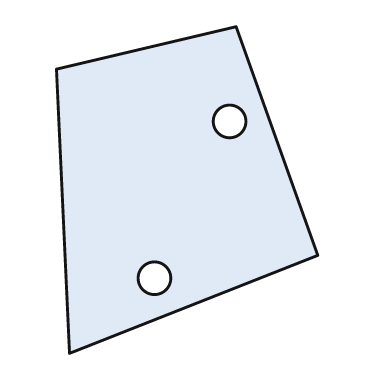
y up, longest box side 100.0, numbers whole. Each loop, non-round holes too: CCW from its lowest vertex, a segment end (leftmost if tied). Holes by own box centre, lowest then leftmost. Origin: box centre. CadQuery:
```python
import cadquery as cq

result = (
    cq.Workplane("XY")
    .moveTo(-36.0, -50.0)
    .lineTo(40.0, -20.0)
    .lineTo(15.0, 50.0)
    .lineTo(-40.0, 37.0)
    .close()
    .moveTo(-10.0, -27.0)
    .circle(5.0)
    .moveTo(13.0, 21.0)
    .circle(5.0)
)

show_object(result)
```